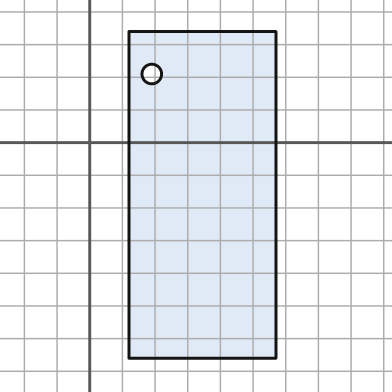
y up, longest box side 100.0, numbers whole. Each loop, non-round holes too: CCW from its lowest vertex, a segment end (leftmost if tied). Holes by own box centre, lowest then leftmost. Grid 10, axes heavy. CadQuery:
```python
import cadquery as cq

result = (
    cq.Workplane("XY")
    .moveTo(12.0, -66.0)
    .lineTo(57.0, -66.0)
    .lineTo(57.0, 34.0)
    .lineTo(12.0, 34.0)
    .close()
    .moveTo(19.0, 21.0)
    .circle(3.0)
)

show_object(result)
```